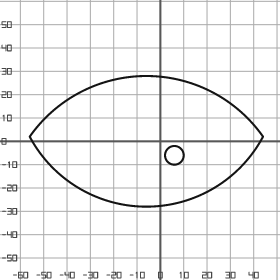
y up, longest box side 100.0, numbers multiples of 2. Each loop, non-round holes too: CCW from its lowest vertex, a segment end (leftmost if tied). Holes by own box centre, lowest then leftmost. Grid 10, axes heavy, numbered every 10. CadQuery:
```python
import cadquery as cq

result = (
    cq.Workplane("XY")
    .moveTo(-56.0, 2.0)
    .threePointArc((-6.0, -28.0), (44.0, 2.0))
    .threePointArc((-6.0, 28.0), (-56.0, 2.0))
    .close()
    .moveTo(6.0, -6.0)
    .circle(4.0)
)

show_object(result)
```